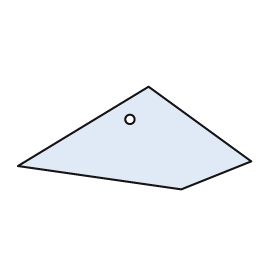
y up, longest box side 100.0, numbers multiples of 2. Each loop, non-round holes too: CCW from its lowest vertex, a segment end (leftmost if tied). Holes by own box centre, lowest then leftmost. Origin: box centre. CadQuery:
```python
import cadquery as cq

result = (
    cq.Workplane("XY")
    .moveTo(20.0, -22.0)
    .lineTo(50.0, -10.0)
    .lineTo(6.0, 22.0)
    .lineTo(-50.0, -12.0)
    .close()
    .moveTo(-2.0, 8.0)
    .circle(2.0)
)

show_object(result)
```